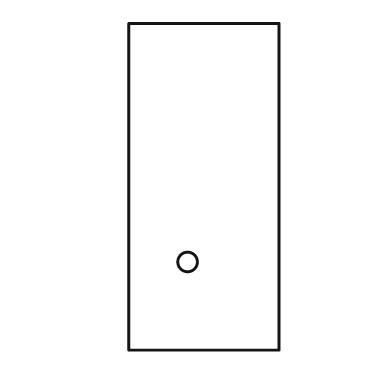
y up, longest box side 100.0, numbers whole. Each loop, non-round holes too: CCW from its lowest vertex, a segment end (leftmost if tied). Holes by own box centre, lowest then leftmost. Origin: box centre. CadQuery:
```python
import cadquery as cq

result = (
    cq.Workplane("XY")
    .moveTo(-23.0, -50.0)
    .lineTo(23.0, -50.0)
    .lineTo(23.0, 50.0)
    .lineTo(-23.0, 50.0)
    .close()
    .moveTo(-5.0, -23.0)
    .circle(3.0)
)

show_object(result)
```